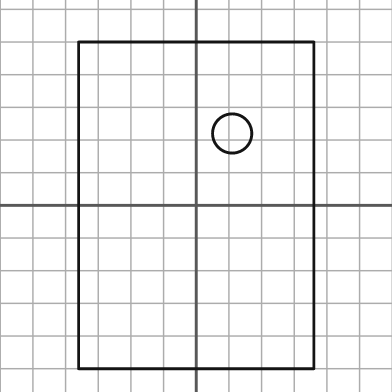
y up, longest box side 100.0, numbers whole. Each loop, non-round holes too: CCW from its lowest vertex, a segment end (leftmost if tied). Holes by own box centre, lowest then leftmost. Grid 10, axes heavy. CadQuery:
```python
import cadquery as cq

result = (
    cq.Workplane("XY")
    .moveTo(-36.0, -50.0)
    .lineTo(36.0, -50.0)
    .lineTo(36.0, 50.0)
    .lineTo(-36.0, 50.0)
    .close()
    .moveTo(11.0, 22.0)
    .circle(6.0)
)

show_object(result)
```